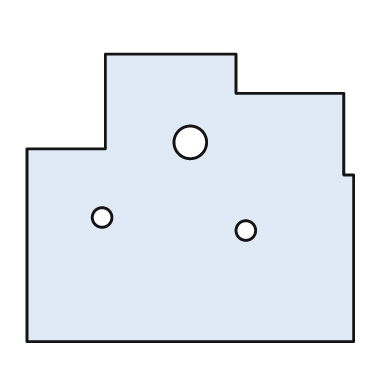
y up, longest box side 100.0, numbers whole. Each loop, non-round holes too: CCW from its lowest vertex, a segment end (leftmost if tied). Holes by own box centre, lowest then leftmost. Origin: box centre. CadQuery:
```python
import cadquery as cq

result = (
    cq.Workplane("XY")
    .moveTo(-50.0, -44.0)
    .lineTo(50.0, -44.0)
    .lineTo(50.0, 7.0)
    .lineTo(47.0, 7.0)
    .lineTo(47.0, 32.0)
    .lineTo(14.0, 32.0)
    .lineTo(14.0, 44.0)
    .lineTo(-26.0, 44.0)
    .lineTo(-26.0, 15.0)
    .lineTo(-50.0, 15.0)
    .close()
    .moveTo(17.0, -10.0)
    .circle(3.0)
    .moveTo(-27.0, -6.0)
    .circle(3.0)
    .moveTo(0.0, 17.0)
    .circle(5.0)
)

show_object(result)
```